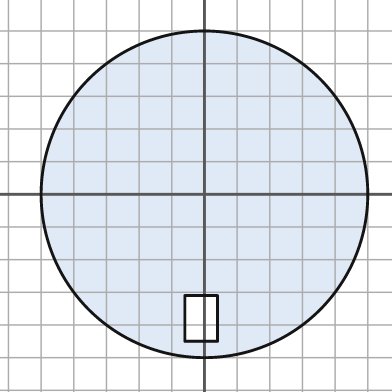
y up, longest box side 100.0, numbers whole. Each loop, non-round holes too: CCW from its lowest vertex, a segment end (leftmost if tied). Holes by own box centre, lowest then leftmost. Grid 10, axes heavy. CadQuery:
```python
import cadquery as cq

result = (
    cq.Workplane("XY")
    .moveTo(0.0, 0.0)
    .circle(50.0)
    .moveTo(-6.0, -45.0)
    .lineTo(4.0, -45.0)
    .lineTo(4.0, -31.0)
    .lineTo(-6.0, -31.0)
    .close()
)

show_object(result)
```